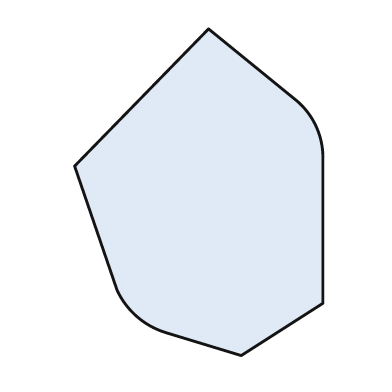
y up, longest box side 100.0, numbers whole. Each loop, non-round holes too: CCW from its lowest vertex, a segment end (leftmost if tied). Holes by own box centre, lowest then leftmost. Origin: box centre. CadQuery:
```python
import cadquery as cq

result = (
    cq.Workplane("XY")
    .moveTo(13.0, -50.0)
    .lineTo(38.0, -34.0)
    .lineTo(38.0, 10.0)
    .threePointArc((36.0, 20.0), (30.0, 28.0))
    .lineTo(3.0, 50.0)
    .lineTo(-38.0, 8.0)
    .lineTo(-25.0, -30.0)
    .threePointArc((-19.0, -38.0), (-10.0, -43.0))
    .close()
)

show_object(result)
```